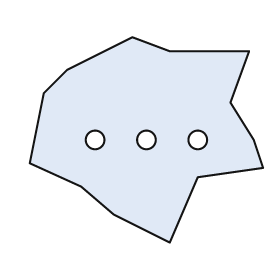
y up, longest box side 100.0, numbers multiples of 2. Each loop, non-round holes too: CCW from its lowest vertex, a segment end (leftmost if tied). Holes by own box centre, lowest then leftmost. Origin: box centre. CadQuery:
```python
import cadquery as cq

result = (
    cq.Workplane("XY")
    .moveTo(10.0, -44.0)
    .lineTo(22.0, -16.0)
    .lineTo(50.0, -12.0)
    .lineTo(46.0, 0.0)
    .lineTo(36.0, 16.0)
    .lineTo(44.0, 38.0)
    .lineTo(10.0, 38.0)
    .lineTo(-6.0, 44.0)
    .lineTo(-34.0, 30.0)
    .lineTo(-44.0, 20.0)
    .lineTo(-50.0, -10.0)
    .lineTo(-28.0, -20.0)
    .lineTo(-14.0, -32.0)
    .close()
    .moveTo(-22.0, 0.0)
    .circle(4.0)
    .moveTo(0.0, 0.0)
    .circle(4.0)
    .moveTo(22.0, 0.0)
    .circle(4.0)
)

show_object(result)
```